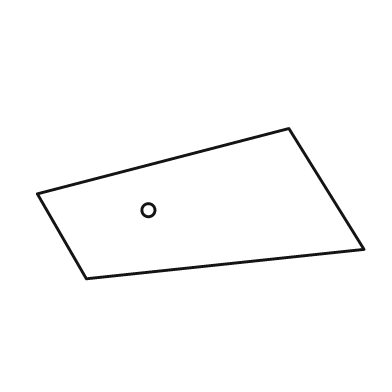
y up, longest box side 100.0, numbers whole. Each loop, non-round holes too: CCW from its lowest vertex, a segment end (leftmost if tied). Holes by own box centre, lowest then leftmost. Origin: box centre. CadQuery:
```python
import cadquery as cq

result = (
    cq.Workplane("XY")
    .moveTo(-35.0, -23.0)
    .lineTo(50.0, -14.0)
    .lineTo(27.0, 23.0)
    .lineTo(-50.0, 3.0)
    .close()
    .moveTo(-16.0, -2.0)
    .circle(2.0)
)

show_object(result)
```